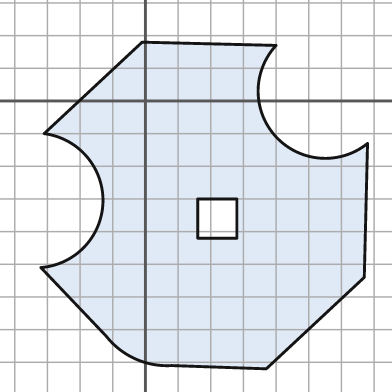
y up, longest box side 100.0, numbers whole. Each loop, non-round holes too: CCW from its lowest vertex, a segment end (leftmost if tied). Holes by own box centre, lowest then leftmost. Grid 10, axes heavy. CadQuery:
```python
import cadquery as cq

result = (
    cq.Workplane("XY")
    .moveTo(37.0, -82.0)
    .lineTo(67.0, -54.0)
    .lineTo(68.0, -13.0)
    .threePointArc((40.0, -11.0), (40.0, 17.0))
    .lineTo(-1.0, 18.0)
    .lineTo(-31.0, -10.0)
    .threePointArc((-13.0, -31.0), (-32.0, -51.0))
    .lineTo(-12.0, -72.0)
    .threePointArc((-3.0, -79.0), (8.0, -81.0))
    .close()
    .moveTo(16.0, -42.0)
    .lineTo(28.0, -42.0)
    .lineTo(28.0, -30.0)
    .lineTo(16.0, -30.0)
    .close()
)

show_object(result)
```